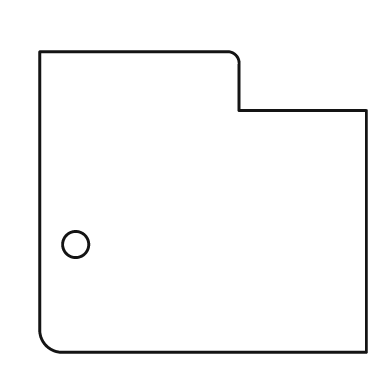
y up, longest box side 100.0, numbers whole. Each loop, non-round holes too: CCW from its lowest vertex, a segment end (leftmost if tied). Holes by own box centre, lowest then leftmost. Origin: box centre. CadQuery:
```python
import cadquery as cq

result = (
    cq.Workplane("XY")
    .moveTo(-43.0, -46.0)
    .lineTo(50.0, -46.0)
    .lineTo(50.0, 28.0)
    .lineTo(11.0, 28.0)
    .lineTo(11.0, 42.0)
    .threePointArc((10.0, 45.0), (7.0, 46.0))
    .lineTo(-50.0, 46.0)
    .lineTo(-50.0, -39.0)
    .threePointArc((-48.0, -44.0), (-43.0, -46.0))
    .close()
    .moveTo(-39.0, -13.0)
    .circle(4.0)
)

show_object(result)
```